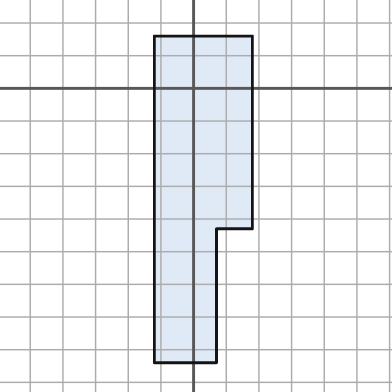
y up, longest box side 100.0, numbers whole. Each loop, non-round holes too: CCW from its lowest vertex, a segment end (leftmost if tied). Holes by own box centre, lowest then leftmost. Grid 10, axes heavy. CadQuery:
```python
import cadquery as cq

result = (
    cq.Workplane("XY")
    .moveTo(-12.0, -84.0)
    .lineTo(7.0, -84.0)
    .lineTo(7.0, -43.0)
    .lineTo(18.0, -43.0)
    .lineTo(18.0, 16.0)
    .lineTo(-12.0, 16.0)
    .close()
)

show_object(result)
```